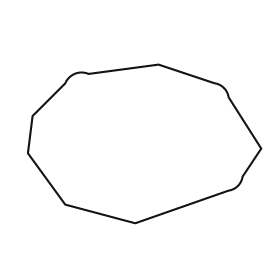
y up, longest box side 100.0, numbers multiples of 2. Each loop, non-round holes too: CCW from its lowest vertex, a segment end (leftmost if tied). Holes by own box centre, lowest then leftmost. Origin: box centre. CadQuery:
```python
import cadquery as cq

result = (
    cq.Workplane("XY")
    .moveTo(-4.0, -34.0)
    .lineTo(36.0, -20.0)
    .threePointArc((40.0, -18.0), (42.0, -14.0))
    .lineTo(50.0, -2.0)
    .lineTo(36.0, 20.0)
    .threePointArc((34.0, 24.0), (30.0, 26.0))
    .lineTo(6.0, 34.0)
    .lineTo(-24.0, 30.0)
    .threePointArc((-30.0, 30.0), (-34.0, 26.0))
    .lineTo(-48.0, 12.0)
    .lineTo(-50.0, -4.0)
    .lineTo(-34.0, -26.0)
    .close()
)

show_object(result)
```